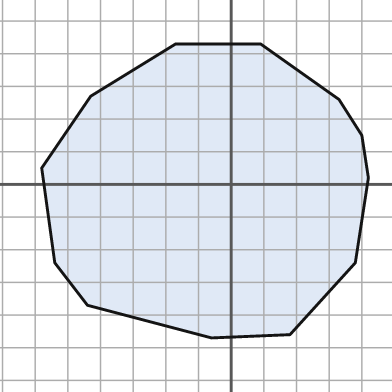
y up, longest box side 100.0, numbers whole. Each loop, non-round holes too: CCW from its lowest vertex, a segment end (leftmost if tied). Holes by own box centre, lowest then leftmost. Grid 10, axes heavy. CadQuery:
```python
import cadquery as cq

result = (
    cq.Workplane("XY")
    .moveTo(-6.0, -47.0)
    .lineTo(18.0, -46.0)
    .lineTo(38.0, -24.0)
    .lineTo(42.0, 2.0)
    .lineTo(40.0, 15.0)
    .lineTo(33.0, 26.0)
    .lineTo(9.0, 43.0)
    .lineTo(-17.0, 43.0)
    .lineTo(-43.0, 27.0)
    .lineTo(-58.0, 5.0)
    .lineTo(-54.0, -24.0)
    .lineTo(-44.0, -37.0)
    .close()
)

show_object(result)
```